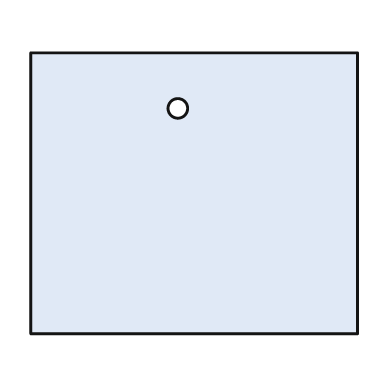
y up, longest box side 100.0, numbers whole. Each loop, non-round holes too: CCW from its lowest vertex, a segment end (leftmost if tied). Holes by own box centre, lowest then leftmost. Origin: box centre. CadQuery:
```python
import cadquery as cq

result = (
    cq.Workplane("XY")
    .moveTo(-50.0, -43.0)
    .lineTo(50.0, -43.0)
    .lineTo(50.0, 43.0)
    .lineTo(-50.0, 43.0)
    .close()
    .moveTo(-5.0, 26.0)
    .circle(3.0)
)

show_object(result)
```